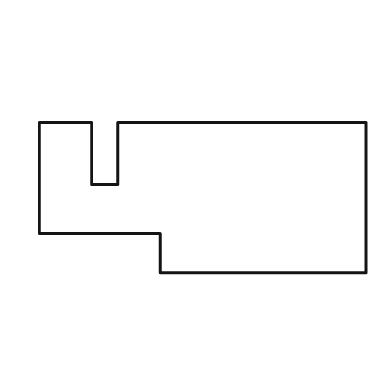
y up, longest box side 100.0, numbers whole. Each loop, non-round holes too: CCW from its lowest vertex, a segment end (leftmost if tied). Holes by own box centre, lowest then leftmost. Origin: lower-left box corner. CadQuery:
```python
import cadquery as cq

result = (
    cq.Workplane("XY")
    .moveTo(37.0, 0.0)
    .lineTo(100.0, 0.0)
    .lineTo(100.0, 46.0)
    .lineTo(24.0, 46.0)
    .lineTo(24.0, 27.0)
    .lineTo(16.0, 27.0)
    .lineTo(16.0, 46.0)
    .lineTo(0.0, 46.0)
    .lineTo(0.0, 12.0)
    .lineTo(37.0, 12.0)
    .close()
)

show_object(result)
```